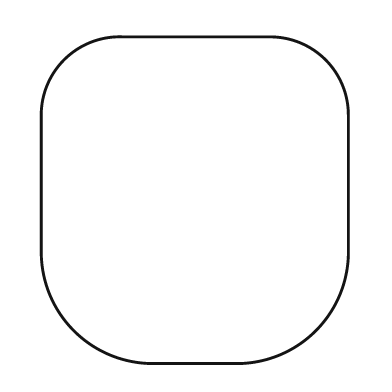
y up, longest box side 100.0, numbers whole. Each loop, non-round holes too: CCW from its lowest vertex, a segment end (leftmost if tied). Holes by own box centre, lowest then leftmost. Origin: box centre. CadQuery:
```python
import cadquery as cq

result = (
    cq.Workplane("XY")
    .moveTo(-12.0, -50.0)
    .lineTo(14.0, -50.0)
    .threePointArc((37.0, -40.0), (47.0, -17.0))
    .lineTo(47.0, 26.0)
    .threePointArc((40.0, 43.0), (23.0, 50.0))
    .lineTo(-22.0, 50.0)
    .threePointArc((-40.0, 43.0), (-47.0, 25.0))
    .lineTo(-47.0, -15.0)
    .threePointArc((-37.0, -40.0), (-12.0, -50.0))
    .close()
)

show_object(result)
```